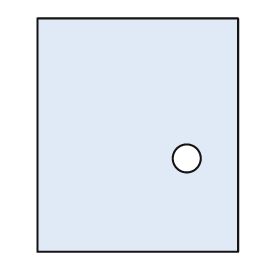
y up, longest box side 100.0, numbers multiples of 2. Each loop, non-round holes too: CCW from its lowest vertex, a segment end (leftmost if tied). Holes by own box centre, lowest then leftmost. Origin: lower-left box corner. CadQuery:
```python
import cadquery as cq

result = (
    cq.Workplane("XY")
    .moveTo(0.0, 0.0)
    .lineTo(86.0, 0.0)
    .lineTo(86.0, 100.0)
    .lineTo(0.0, 100.0)
    .close()
    .moveTo(64.0, 40.0)
    .circle(6.0)
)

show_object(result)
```